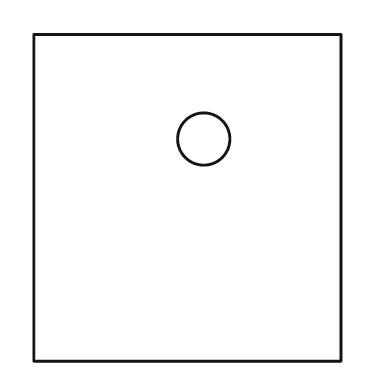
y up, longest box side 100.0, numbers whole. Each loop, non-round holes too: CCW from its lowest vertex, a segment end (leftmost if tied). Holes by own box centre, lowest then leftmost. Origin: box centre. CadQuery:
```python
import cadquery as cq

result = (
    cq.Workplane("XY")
    .moveTo(-47.0, -50.0)
    .lineTo(47.0, -50.0)
    .lineTo(47.0, 50.0)
    .lineTo(-47.0, 50.0)
    .close()
    .moveTo(5.0, 18.0)
    .circle(8.0)
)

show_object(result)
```